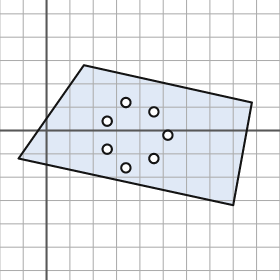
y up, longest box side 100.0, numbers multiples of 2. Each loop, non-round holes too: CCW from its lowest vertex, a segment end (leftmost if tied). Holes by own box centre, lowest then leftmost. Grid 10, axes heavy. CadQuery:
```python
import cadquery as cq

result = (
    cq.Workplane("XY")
    .moveTo(80.0, -32.0)
    .lineTo(88.0, 12.0)
    .lineTo(16.0, 28.0)
    .lineTo(-12.0, -12.0)
    .close()
    .moveTo(34.0, -16.0)
    .circle(2.0)
    .moveTo(46.0, -12.0)
    .circle(2.0)
    .moveTo(26.0, -8.0)
    .circle(2.0)
    .moveTo(52.0, -2.0)
    .circle(2.0)
    .moveTo(26.0, 4.0)
    .circle(2.0)
    .moveTo(46.0, 8.0)
    .circle(2.0)
    .moveTo(34.0, 12.0)
    .circle(2.0)
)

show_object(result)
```